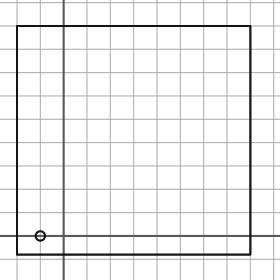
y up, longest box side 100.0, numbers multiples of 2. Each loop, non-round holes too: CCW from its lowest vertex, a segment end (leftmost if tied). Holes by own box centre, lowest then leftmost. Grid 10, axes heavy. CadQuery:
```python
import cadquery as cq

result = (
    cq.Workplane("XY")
    .moveTo(-20.0, -8.0)
    .lineTo(80.0, -8.0)
    .lineTo(80.0, 90.0)
    .lineTo(-20.0, 90.0)
    .close()
    .moveTo(-10.0, 0.0)
    .circle(2.0)
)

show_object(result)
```